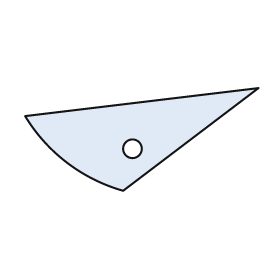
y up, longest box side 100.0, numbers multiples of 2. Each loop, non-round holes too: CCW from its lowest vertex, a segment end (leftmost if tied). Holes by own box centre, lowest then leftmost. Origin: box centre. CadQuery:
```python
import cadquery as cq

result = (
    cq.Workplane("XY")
    .moveTo(-8.0, -22.0)
    .lineTo(50.0, 22.0)
    .lineTo(-50.0, 10.0)
    .threePointArc((-32.0, -10.0), (-8.0, -22.0))
    .close()
    .moveTo(-4.0, -4.0)
    .circle(4.0)
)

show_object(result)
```